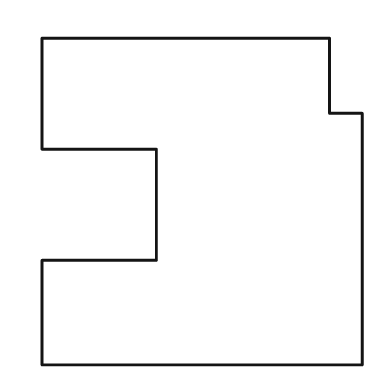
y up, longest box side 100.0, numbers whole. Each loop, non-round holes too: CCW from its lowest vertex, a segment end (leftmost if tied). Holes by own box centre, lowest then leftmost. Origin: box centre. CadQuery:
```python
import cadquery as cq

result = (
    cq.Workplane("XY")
    .moveTo(-49.0, -50.0)
    .lineTo(49.0, -50.0)
    .lineTo(49.0, 27.0)
    .lineTo(39.0, 27.0)
    .lineTo(39.0, 50.0)
    .lineTo(-49.0, 50.0)
    .lineTo(-49.0, 16.0)
    .lineTo(-14.0, 16.0)
    .lineTo(-14.0, -18.0)
    .lineTo(-49.0, -18.0)
    .close()
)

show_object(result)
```